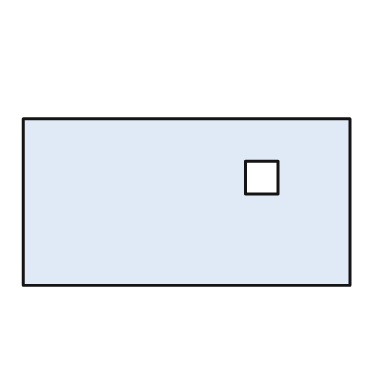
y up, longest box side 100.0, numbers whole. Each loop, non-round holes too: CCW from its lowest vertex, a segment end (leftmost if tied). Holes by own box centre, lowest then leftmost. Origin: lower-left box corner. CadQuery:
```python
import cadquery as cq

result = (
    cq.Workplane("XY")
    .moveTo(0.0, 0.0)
    .lineTo(100.0, 0.0)
    .lineTo(100.0, 51.0)
    .lineTo(0.0, 51.0)
    .close()
    .moveTo(68.0, 28.0)
    .lineTo(78.0, 28.0)
    .lineTo(78.0, 38.0)
    .lineTo(68.0, 38.0)
    .close()
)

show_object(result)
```